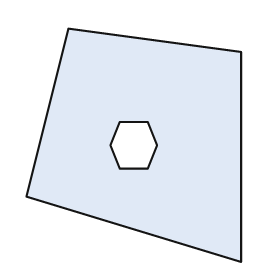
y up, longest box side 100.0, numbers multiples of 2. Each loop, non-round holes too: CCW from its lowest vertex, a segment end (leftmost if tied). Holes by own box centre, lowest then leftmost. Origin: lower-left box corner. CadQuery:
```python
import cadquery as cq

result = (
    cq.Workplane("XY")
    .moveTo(92.0, 0.0)
    .lineTo(92.0, 90.0)
    .lineTo(18.0, 100.0)
    .lineTo(0.0, 28.0)
    .close()
    .moveTo(40.0, 40.0)
    .lineTo(52.0, 40.0)
    .lineTo(56.0, 50.0)
    .lineTo(52.0, 60.0)
    .lineTo(40.0, 60.0)
    .lineTo(36.0, 50.0)
    .close()
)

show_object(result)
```